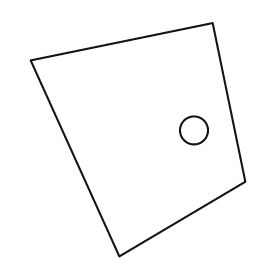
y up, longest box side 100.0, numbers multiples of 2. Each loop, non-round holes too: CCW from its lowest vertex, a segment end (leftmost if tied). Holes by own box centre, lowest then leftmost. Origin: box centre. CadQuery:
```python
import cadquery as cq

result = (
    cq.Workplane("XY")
    .moveTo(-8.0, -50.0)
    .lineTo(46.0, -18.0)
    .lineTo(32.0, 50.0)
    .lineTo(-46.0, 34.0)
    .close()
    .moveTo(24.0, 4.0)
    .circle(6.0)
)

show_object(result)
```